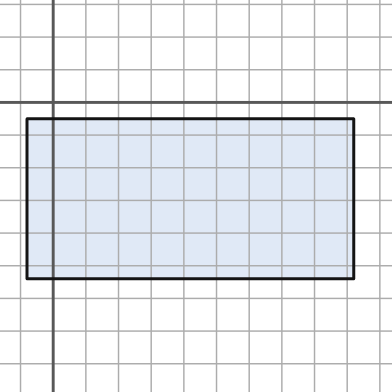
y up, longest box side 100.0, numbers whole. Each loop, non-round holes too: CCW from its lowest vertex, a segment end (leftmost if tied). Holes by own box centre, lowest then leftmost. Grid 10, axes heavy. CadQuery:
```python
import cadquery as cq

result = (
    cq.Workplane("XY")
    .moveTo(-8.0, -54.0)
    .lineTo(92.0, -54.0)
    .lineTo(92.0, -5.0)
    .lineTo(-8.0, -5.0)
    .close()
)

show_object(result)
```